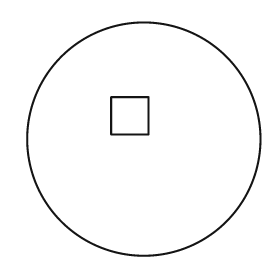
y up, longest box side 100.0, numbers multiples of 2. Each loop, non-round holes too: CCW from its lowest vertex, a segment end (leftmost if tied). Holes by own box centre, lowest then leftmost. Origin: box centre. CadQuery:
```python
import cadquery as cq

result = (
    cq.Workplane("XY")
    .moveTo(0.0, 0.0)
    .circle(50.0)
    .moveTo(-14.0, 2.0)
    .lineTo(2.0, 2.0)
    .lineTo(2.0, 18.0)
    .lineTo(-14.0, 18.0)
    .close()
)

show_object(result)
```